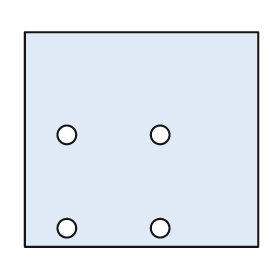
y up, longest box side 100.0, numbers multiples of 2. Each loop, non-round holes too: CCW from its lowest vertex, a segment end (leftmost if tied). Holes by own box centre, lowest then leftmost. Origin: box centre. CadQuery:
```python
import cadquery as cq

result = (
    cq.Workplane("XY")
    .moveTo(-50.0, -46.0)
    .lineTo(50.0, -46.0)
    .lineTo(50.0, 46.0)
    .lineTo(-50.0, 46.0)
    .close()
    .moveTo(-32.0, -38.0)
    .circle(4.0)
    .moveTo(8.0, -38.0)
    .circle(4.0)
    .moveTo(-32.0, 2.0)
    .circle(4.0)
    .moveTo(8.0, 2.0)
    .circle(4.0)
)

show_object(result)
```